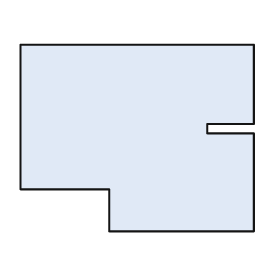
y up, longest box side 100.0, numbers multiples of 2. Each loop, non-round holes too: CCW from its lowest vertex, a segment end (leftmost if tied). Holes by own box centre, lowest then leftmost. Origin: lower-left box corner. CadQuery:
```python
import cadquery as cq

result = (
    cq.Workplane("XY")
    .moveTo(38.0, 0.0)
    .lineTo(100.0, 0.0)
    .lineTo(100.0, 42.0)
    .lineTo(80.0, 42.0)
    .lineTo(80.0, 46.0)
    .lineTo(100.0, 46.0)
    .lineTo(100.0, 80.0)
    .lineTo(0.0, 80.0)
    .lineTo(0.0, 18.0)
    .lineTo(38.0, 18.0)
    .close()
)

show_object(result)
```